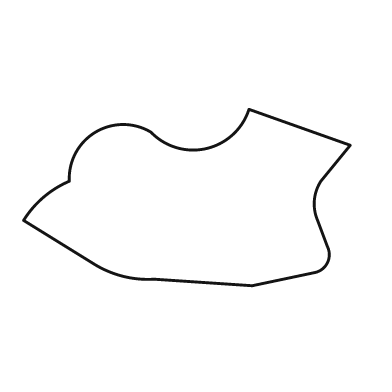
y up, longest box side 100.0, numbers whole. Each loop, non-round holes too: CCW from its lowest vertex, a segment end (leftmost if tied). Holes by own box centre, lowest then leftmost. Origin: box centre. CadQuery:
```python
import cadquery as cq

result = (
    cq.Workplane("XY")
    .moveTo(20.0, -27.0)
    .lineTo(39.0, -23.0)
    .threePointArc((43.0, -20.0), (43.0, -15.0))
    .lineTo(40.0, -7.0)
    .threePointArc((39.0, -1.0), (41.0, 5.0))
    .lineTo(50.0, 16.0)
    .lineTo(19.0, 27.0)
    .threePointArc((6.0, 15.0), (-11.0, 20.0))
    .threePointArc((-28.0, 20.0), (-36.0, 5.0))
    .threePointArc((-44.0, 0.0), (-50.0, -7.0))
    .lineTo(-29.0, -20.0)
    .threePointArc((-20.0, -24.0), (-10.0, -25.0))
    .close()
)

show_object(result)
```